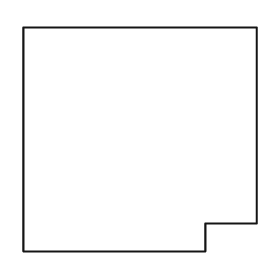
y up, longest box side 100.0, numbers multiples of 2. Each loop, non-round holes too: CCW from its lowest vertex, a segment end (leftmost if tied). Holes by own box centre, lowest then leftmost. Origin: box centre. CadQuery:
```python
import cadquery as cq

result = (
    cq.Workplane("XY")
    .moveTo(-50.0, -48.0)
    .lineTo(28.0, -48.0)
    .lineTo(28.0, -36.0)
    .lineTo(50.0, -36.0)
    .lineTo(50.0, 48.0)
    .lineTo(-50.0, 48.0)
    .close()
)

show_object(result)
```